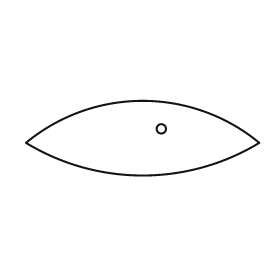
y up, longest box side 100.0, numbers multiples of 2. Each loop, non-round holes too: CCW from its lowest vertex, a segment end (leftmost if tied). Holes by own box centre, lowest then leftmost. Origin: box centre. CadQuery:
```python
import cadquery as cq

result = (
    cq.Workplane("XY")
    .moveTo(-50.0, -2.0)
    .threePointArc((0.0, -16.0), (50.0, -2.0))
    .threePointArc((0.0, 16.0), (-50.0, -2.0))
    .close()
    .moveTo(8.0, 4.0)
    .circle(2.0)
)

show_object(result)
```